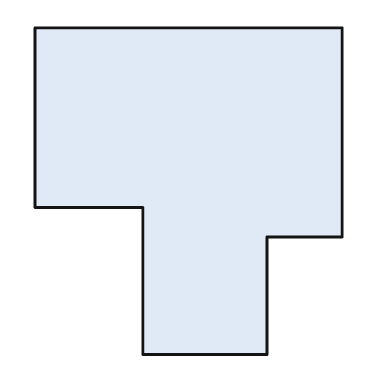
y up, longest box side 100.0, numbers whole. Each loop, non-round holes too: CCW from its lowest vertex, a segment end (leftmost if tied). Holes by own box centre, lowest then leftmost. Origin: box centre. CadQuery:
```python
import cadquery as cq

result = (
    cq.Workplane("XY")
    .moveTo(-14.0, -50.0)
    .lineTo(24.0, -50.0)
    .lineTo(24.0, -14.0)
    .lineTo(47.0, -14.0)
    .lineTo(47.0, 50.0)
    .lineTo(-47.0, 50.0)
    .lineTo(-47.0, -5.0)
    .lineTo(-14.0, -5.0)
    .close()
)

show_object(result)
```